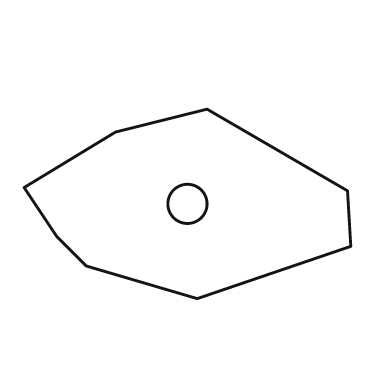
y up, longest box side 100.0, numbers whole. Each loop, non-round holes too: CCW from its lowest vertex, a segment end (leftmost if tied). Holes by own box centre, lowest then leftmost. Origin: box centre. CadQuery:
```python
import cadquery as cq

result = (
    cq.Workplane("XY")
    .moveTo(3.0, -29.0)
    .lineTo(50.0, -13.0)
    .lineTo(49.0, 4.0)
    .lineTo(6.0, 29.0)
    .lineTo(-22.0, 22.0)
    .lineTo(-50.0, 5.0)
    .lineTo(-40.0, -10.0)
    .lineTo(-31.0, -19.0)
    .close()
    .moveTo(0.0, 0.0)
    .circle(6.0)
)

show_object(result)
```